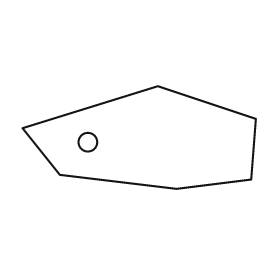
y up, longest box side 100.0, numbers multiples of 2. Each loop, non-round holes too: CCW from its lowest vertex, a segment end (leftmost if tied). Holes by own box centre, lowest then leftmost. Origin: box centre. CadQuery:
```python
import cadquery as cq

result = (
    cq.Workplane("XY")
    .moveTo(16.0, -22.0)
    .lineTo(48.0, -18.0)
    .lineTo(50.0, 8.0)
    .lineTo(8.0, 22.0)
    .lineTo(-50.0, 4.0)
    .lineTo(-34.0, -16.0)
    .close()
    .moveTo(-22.0, -2.0)
    .circle(4.0)
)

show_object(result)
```